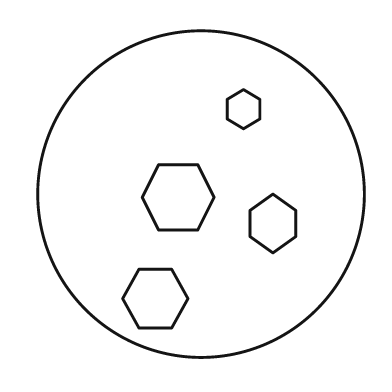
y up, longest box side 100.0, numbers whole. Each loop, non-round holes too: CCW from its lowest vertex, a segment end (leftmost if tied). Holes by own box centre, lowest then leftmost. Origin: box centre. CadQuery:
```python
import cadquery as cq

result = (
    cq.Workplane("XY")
    .moveTo(0.0, 0.0)
    .circle(50.0)
    .moveTo(-19.0, -41.0)
    .lineTo(-9.0, -41.0)
    .lineTo(-4.0, -32.0)
    .lineTo(-9.0, -23.0)
    .lineTo(-19.0, -23.0)
    .lineTo(-24.0, -32.0)
    .close()
    .moveTo(22.0, -18.0)
    .lineTo(29.0, -13.0)
    .lineTo(29.0, -5.0)
    .lineTo(22.0, 0.0)
    .lineTo(15.0, -5.0)
    .lineTo(15.0, -13.0)
    .close()
    .moveTo(-13.0, -11.0)
    .lineTo(-1.0, -11.0)
    .lineTo(4.0, -1.0)
    .lineTo(-1.0, 9.0)
    .lineTo(-13.0, 9.0)
    .lineTo(-18.0, -1.0)
    .close()
    .moveTo(13.0, 20.0)
    .lineTo(18.0, 23.0)
    .lineTo(18.0, 29.0)
    .lineTo(13.0, 32.0)
    .lineTo(8.0, 29.0)
    .lineTo(8.0, 23.0)
    .close()
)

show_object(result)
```